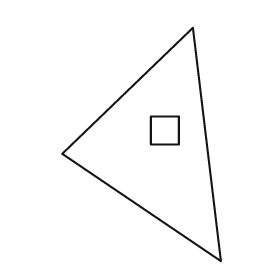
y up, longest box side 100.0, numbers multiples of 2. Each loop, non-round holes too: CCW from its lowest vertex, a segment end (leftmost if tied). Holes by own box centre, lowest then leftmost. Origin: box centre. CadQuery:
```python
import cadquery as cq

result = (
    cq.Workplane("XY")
    .moveTo(34.0, -50.0)
    .lineTo(22.0, 50.0)
    .lineTo(-34.0, -4.0)
    .close()
    .moveTo(4.0, 0.0)
    .lineTo(16.0, 0.0)
    .lineTo(16.0, 12.0)
    .lineTo(4.0, 12.0)
    .close()
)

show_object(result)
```